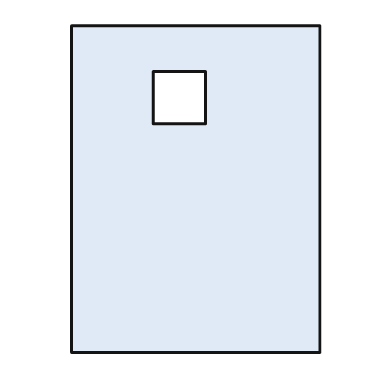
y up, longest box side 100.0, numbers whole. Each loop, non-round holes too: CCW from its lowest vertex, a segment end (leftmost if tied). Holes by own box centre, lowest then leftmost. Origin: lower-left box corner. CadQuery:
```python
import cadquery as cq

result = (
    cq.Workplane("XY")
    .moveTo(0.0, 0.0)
    .lineTo(76.0, 0.0)
    .lineTo(76.0, 100.0)
    .lineTo(0.0, 100.0)
    .close()
    .moveTo(25.0, 70.0)
    .lineTo(41.0, 70.0)
    .lineTo(41.0, 86.0)
    .lineTo(25.0, 86.0)
    .close()
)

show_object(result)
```